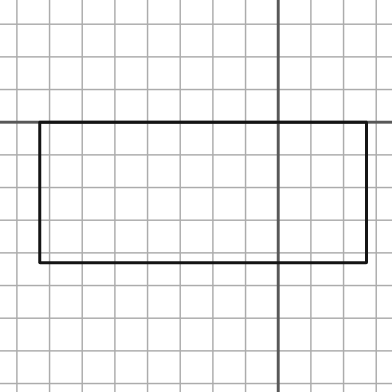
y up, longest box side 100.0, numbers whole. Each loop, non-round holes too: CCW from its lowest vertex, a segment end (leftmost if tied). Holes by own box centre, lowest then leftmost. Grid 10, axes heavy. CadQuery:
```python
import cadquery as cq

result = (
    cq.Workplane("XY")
    .moveTo(-73.0, -43.0)
    .lineTo(27.0, -43.0)
    .lineTo(27.0, 0.0)
    .lineTo(-73.0, 0.0)
    .close()
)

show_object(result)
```